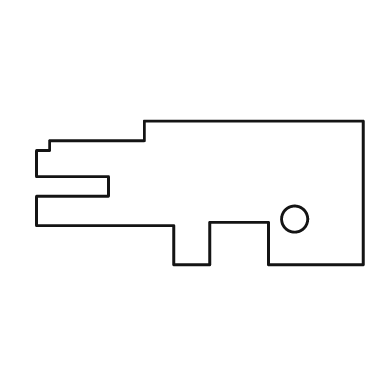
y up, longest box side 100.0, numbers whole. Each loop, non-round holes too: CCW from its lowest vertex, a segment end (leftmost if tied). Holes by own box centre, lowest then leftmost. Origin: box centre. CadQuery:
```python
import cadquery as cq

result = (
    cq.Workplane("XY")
    .moveTo(-8.0, -22.0)
    .lineTo(3.0, -22.0)
    .lineTo(3.0, -9.0)
    .lineTo(21.0, -9.0)
    .lineTo(21.0, -22.0)
    .lineTo(50.0, -22.0)
    .lineTo(50.0, 22.0)
    .lineTo(-17.0, 22.0)
    .lineTo(-17.0, 16.0)
    .lineTo(-46.0, 16.0)
    .lineTo(-46.0, 13.0)
    .lineTo(-50.0, 13.0)
    .lineTo(-50.0, 5.0)
    .lineTo(-28.0, 5.0)
    .lineTo(-28.0, -1.0)
    .lineTo(-50.0, -1.0)
    .lineTo(-50.0, -10.0)
    .lineTo(-8.0, -10.0)
    .close()
    .moveTo(29.0, -8.0)
    .circle(4.0)
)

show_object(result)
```